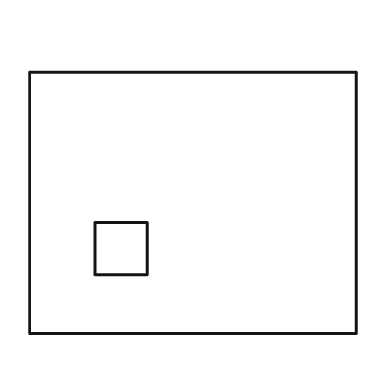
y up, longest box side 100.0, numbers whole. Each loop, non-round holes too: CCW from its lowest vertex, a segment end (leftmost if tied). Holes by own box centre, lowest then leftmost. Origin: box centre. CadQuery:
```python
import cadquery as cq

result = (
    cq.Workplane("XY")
    .moveTo(-50.0, -40.0)
    .lineTo(50.0, -40.0)
    .lineTo(50.0, 40.0)
    .lineTo(-50.0, 40.0)
    .close()
    .moveTo(-30.0, -22.0)
    .lineTo(-14.0, -22.0)
    .lineTo(-14.0, -6.0)
    .lineTo(-30.0, -6.0)
    .close()
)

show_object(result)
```